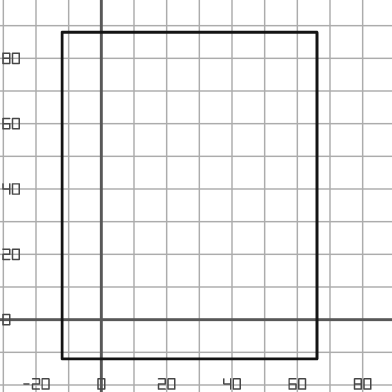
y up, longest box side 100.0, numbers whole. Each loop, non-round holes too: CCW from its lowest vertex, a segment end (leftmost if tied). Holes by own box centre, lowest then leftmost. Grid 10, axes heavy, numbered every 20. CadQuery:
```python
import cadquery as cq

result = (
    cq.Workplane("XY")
    .moveTo(-12.0, -12.0)
    .lineTo(66.0, -12.0)
    .lineTo(66.0, 88.0)
    .lineTo(-12.0, 88.0)
    .close()
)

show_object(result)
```